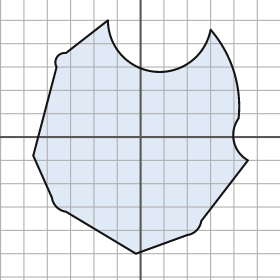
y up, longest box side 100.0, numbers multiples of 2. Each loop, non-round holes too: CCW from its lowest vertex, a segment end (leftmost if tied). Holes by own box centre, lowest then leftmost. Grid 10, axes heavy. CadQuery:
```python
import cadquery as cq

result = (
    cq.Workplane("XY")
    .moveTo(-2.0, -50.0)
    .lineTo(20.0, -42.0)
    .threePointArc((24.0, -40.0), (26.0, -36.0))
    .lineTo(46.0, -10.0)
    .threePointArc((40.0, -2.0), (42.0, 8.0))
    .threePointArc((40.0, 28.0), (30.0, 46.0))
    .threePointArc((6.0, 28.0), (-14.0, 50.0))
    .lineTo(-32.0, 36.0)
    .threePointArc((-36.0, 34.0), (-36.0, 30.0))
    .lineTo(-46.0, -8.0)
    .lineTo(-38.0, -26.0)
    .threePointArc((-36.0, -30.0), (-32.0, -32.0))
    .close()
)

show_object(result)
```